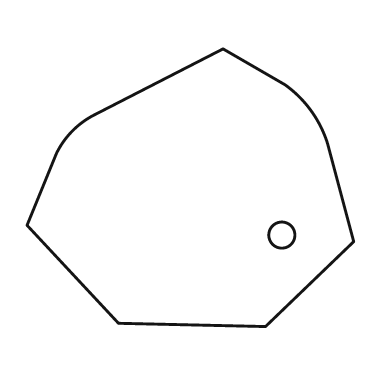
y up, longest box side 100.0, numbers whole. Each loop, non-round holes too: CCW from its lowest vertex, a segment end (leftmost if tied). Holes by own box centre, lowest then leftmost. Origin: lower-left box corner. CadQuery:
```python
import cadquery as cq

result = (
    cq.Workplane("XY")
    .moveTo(73.0, 0.0)
    .lineTo(100.0, 26.0)
    .lineTo(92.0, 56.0)
    .threePointArc((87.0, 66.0), (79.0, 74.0))
    .lineTo(60.0, 85.0)
    .lineTo(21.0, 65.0)
    .threePointArc((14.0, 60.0), (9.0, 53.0))
    .lineTo(0.0, 31.0)
    .lineTo(28.0, 1.0)
    .close()
    .moveTo(78.0, 28.0)
    .circle(4.0)
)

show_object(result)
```